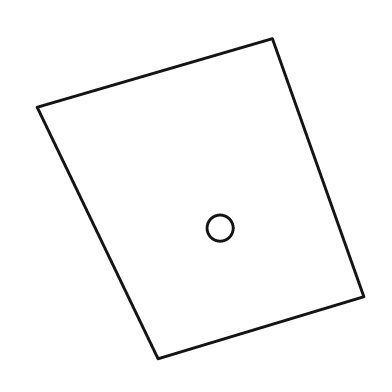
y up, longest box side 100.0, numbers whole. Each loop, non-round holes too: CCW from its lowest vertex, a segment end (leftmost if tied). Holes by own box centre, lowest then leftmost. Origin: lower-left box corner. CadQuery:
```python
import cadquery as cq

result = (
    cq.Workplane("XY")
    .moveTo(37.0, 0.0)
    .lineTo(100.0, 19.0)
    .lineTo(72.0, 98.0)
    .lineTo(0.0, 77.0)
    .close()
    .moveTo(56.0, 40.0)
    .circle(4.0)
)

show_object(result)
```